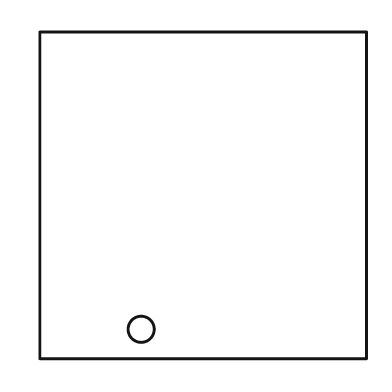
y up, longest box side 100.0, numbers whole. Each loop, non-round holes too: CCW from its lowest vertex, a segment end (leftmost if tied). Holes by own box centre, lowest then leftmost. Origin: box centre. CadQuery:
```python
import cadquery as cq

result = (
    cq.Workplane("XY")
    .moveTo(-50.0, -50.0)
    .lineTo(50.0, -50.0)
    .lineTo(50.0, 50.0)
    .lineTo(-50.0, 50.0)
    .close()
    .moveTo(-19.0, -41.0)
    .circle(4.0)
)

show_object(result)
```